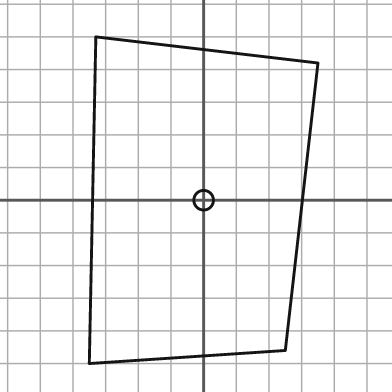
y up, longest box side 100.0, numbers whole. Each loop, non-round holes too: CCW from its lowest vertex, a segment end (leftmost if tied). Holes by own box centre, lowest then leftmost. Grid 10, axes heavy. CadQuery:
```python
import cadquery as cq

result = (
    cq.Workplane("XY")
    .moveTo(-35.0, -50.0)
    .lineTo(25.0, -46.0)
    .lineTo(35.0, 42.0)
    .lineTo(-33.0, 50.0)
    .close()
    .moveTo(0.0, 0.0)
    .circle(3.0)
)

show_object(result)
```